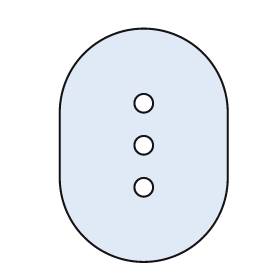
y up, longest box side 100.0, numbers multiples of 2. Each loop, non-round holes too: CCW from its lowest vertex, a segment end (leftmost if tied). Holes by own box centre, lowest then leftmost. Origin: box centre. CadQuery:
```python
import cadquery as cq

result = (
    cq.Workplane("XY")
    .moveTo(-36.0, -14.0)
    .threePointArc((0.0, -50.0), (36.0, -14.0))
    .lineTo(36.0, 14.0)
    .threePointArc((0.0, 50.0), (-36.0, 14.0))
    .close()
    .moveTo(0.0, -18.0)
    .circle(4.0)
    .moveTo(0.0, 0.0)
    .circle(4.0)
    .moveTo(0.0, 18.0)
    .circle(4.0)
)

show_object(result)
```